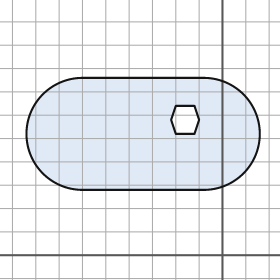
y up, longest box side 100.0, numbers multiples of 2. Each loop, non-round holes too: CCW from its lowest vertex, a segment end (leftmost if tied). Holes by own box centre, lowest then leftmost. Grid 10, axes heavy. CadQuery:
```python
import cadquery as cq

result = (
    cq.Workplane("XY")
    .moveTo(-60.0, 28.0)
    .lineTo(-8.0, 28.0)
    .threePointArc((16.0, 52.0), (-8.0, 76.0))
    .lineTo(-60.0, 76.0)
    .threePointArc((-84.0, 52.0), (-60.0, 28.0))
    .close()
    .moveTo(-20.0, 52.0)
    .lineTo(-12.0, 52.0)
    .lineTo(-10.0, 58.0)
    .lineTo(-12.0, 64.0)
    .lineTo(-20.0, 64.0)
    .lineTo(-22.0, 58.0)
    .close()
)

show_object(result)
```